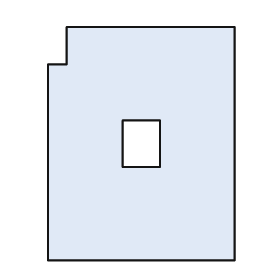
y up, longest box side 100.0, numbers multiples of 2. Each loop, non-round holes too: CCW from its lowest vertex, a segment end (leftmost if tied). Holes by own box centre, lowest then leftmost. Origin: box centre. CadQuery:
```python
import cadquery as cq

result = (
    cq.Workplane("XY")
    .moveTo(-40.0, -50.0)
    .lineTo(40.0, -50.0)
    .lineTo(40.0, 50.0)
    .lineTo(-32.0, 50.0)
    .lineTo(-32.0, 34.0)
    .lineTo(-40.0, 34.0)
    .close()
    .moveTo(-8.0, -10.0)
    .lineTo(8.0, -10.0)
    .lineTo(8.0, 10.0)
    .lineTo(-8.0, 10.0)
    .close()
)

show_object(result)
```